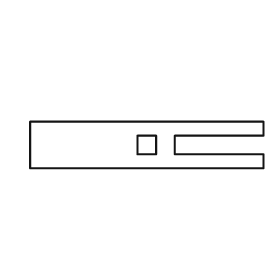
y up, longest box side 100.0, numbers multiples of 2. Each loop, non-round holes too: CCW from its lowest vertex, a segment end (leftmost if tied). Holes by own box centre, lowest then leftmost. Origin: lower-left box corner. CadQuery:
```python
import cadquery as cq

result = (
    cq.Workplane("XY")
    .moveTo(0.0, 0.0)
    .lineTo(100.0, 0.0)
    .lineTo(100.0, 6.0)
    .lineTo(62.0, 6.0)
    .lineTo(62.0, 14.0)
    .lineTo(100.0, 14.0)
    .lineTo(100.0, 20.0)
    .lineTo(0.0, 20.0)
    .close()
    .moveTo(46.0, 6.0)
    .lineTo(54.0, 6.0)
    .lineTo(54.0, 14.0)
    .lineTo(46.0, 14.0)
    .close()
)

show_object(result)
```